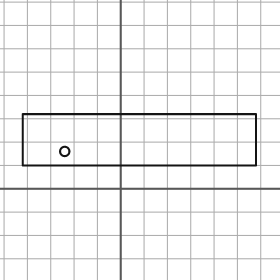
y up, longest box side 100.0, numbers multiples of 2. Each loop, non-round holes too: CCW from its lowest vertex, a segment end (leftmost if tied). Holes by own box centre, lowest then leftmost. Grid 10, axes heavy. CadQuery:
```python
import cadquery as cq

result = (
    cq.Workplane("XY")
    .moveTo(-42.0, 10.0)
    .lineTo(58.0, 10.0)
    .lineTo(58.0, 32.0)
    .lineTo(-42.0, 32.0)
    .close()
    .moveTo(-24.0, 16.0)
    .circle(2.0)
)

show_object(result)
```